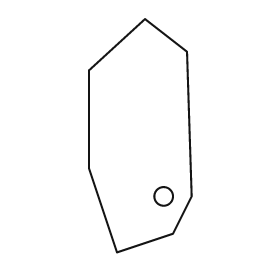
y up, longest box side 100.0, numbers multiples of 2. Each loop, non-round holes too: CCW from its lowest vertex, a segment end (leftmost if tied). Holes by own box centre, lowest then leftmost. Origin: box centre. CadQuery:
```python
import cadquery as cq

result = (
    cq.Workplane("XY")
    .moveTo(-10.0, -50.0)
    .lineTo(14.0, -42.0)
    .lineTo(22.0, -26.0)
    .lineTo(20.0, 36.0)
    .lineTo(2.0, 50.0)
    .lineTo(-22.0, 28.0)
    .lineTo(-22.0, -14.0)
    .close()
    .moveTo(10.0, -26.0)
    .circle(4.0)
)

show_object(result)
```